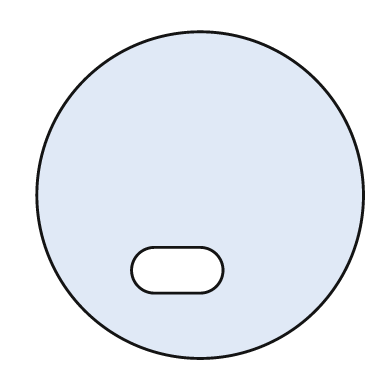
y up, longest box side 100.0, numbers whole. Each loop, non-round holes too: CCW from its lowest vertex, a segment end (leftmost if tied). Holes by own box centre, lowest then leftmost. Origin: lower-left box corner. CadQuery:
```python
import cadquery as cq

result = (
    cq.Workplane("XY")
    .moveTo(50.0, 50.0)
    .circle(50.0)
    .moveTo(36.0, 20.0)
    .lineTo(50.0, 20.0)
    .threePointArc((57.0, 27.0), (50.0, 34.0))
    .lineTo(36.0, 34.0)
    .threePointArc((29.0, 27.0), (36.0, 20.0))
    .close()
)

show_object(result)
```